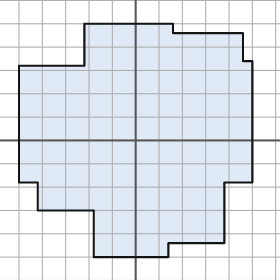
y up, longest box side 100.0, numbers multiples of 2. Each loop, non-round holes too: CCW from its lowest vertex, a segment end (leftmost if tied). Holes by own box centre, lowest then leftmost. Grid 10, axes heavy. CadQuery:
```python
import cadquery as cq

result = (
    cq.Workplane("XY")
    .moveTo(-18.0, -50.0)
    .lineTo(14.0, -50.0)
    .lineTo(14.0, -44.0)
    .lineTo(38.0, -44.0)
    .lineTo(38.0, -18.0)
    .lineTo(50.0, -18.0)
    .lineTo(50.0, 34.0)
    .lineTo(46.0, 34.0)
    .lineTo(46.0, 46.0)
    .lineTo(16.0, 46.0)
    .lineTo(16.0, 50.0)
    .lineTo(-22.0, 50.0)
    .lineTo(-22.0, 32.0)
    .lineTo(-50.0, 32.0)
    .lineTo(-50.0, -18.0)
    .lineTo(-42.0, -18.0)
    .lineTo(-42.0, -30.0)
    .lineTo(-18.0, -30.0)
    .close()
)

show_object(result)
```